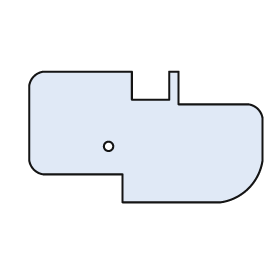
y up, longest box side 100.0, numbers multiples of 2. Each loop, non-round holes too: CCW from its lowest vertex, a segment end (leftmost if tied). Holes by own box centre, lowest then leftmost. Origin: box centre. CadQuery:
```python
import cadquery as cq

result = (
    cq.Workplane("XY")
    .moveTo(-10.0, -28.0)
    .lineTo(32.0, -28.0)
    .threePointArc((44.0, -22.0), (50.0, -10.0))
    .lineTo(50.0, 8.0)
    .threePointArc((48.0, 12.0), (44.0, 14.0))
    .lineTo(14.0, 14.0)
    .lineTo(14.0, 28.0)
    .lineTo(10.0, 28.0)
    .lineTo(10.0, 16.0)
    .lineTo(-6.0, 16.0)
    .lineTo(-6.0, 28.0)
    .lineTo(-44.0, 28.0)
    .threePointArc((-48.0, 26.0), (-50.0, 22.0))
    .lineTo(-50.0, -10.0)
    .threePointArc((-48.0, -14.0), (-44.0, -16.0))
    .lineTo(-10.0, -16.0)
    .close()
    .moveTo(-16.0, -4.0)
    .circle(2.0)
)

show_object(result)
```